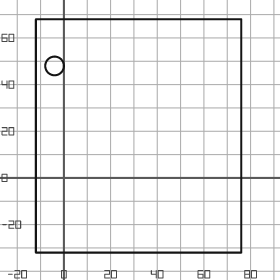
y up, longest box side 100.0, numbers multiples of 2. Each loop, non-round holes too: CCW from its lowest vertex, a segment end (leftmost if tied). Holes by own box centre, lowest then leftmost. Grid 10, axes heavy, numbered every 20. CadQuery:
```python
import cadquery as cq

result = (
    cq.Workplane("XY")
    .moveTo(-12.0, -32.0)
    .lineTo(76.0, -32.0)
    .lineTo(76.0, 68.0)
    .lineTo(-12.0, 68.0)
    .close()
    .moveTo(-4.0, 48.0)
    .circle(4.0)
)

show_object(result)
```